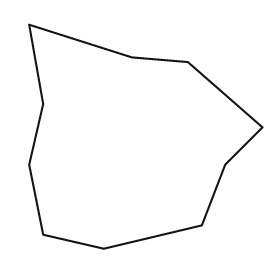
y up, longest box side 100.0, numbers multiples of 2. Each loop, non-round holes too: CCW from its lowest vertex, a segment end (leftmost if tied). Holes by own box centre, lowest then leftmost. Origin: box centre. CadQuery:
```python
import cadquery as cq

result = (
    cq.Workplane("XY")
    .moveTo(-18.0, -48.0)
    .lineTo(24.0, -38.0)
    .lineTo(34.0, -12.0)
    .lineTo(50.0, 4.0)
    .lineTo(18.0, 32.0)
    .lineTo(-6.0, 34.0)
    .lineTo(-50.0, 48.0)
    .lineTo(-44.0, 14.0)
    .lineTo(-50.0, -12.0)
    .lineTo(-44.0, -42.0)
    .close()
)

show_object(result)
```